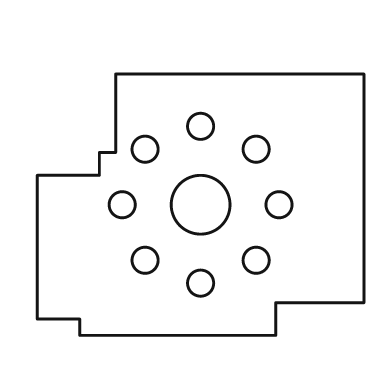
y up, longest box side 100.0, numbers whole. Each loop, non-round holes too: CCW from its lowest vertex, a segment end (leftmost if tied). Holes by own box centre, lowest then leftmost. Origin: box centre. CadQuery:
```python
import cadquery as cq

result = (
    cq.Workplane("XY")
    .moveTo(-37.0, -40.0)
    .lineTo(23.0, -40.0)
    .lineTo(23.0, -30.0)
    .lineTo(50.0, -30.0)
    .lineTo(50.0, 40.0)
    .lineTo(-26.0, 40.0)
    .lineTo(-26.0, 16.0)
    .lineTo(-31.0, 16.0)
    .lineTo(-31.0, 9.0)
    .lineTo(-50.0, 9.0)
    .lineTo(-50.0, -35.0)
    .lineTo(-37.0, -35.0)
    .close()
    .moveTo(0.0, -24.0)
    .circle(4.0)
    .moveTo(-17.0, -17.0)
    .circle(4.0)
    .moveTo(17.0, -17.0)
    .circle(4.0)
    .moveTo(-24.0, 0.0)
    .circle(4.0)
    .moveTo(0.0, 0.0)
    .circle(9.0)
    .moveTo(24.0, 0.0)
    .circle(4.0)
    .moveTo(-17.0, 17.0)
    .circle(4.0)
    .moveTo(17.0, 17.0)
    .circle(4.0)
    .moveTo(0.0, 24.0)
    .circle(4.0)
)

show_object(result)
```